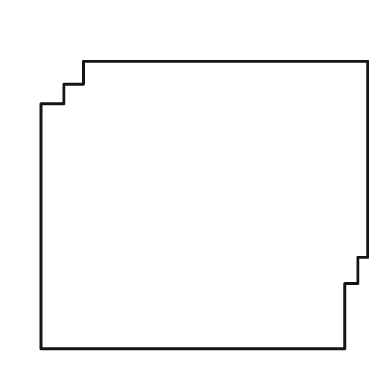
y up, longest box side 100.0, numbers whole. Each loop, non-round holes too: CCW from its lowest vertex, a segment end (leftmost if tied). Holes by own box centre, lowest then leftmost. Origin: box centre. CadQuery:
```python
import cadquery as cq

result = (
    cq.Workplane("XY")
    .moveTo(-50.0, -44.0)
    .lineTo(43.0, -44.0)
    .lineTo(43.0, -24.0)
    .lineTo(47.0, -24.0)
    .lineTo(47.0, -16.0)
    .lineTo(50.0, -16.0)
    .lineTo(50.0, 44.0)
    .lineTo(-37.0, 44.0)
    .lineTo(-37.0, 37.0)
    .lineTo(-43.0, 37.0)
    .lineTo(-43.0, 31.0)
    .lineTo(-50.0, 31.0)
    .close()
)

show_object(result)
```